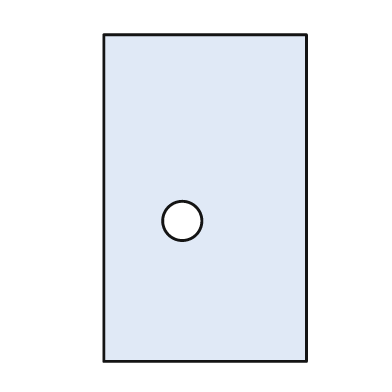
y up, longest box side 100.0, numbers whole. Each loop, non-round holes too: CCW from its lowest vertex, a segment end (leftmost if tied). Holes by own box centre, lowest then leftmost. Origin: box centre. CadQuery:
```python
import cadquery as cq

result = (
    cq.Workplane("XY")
    .moveTo(-31.0, -50.0)
    .lineTo(31.0, -50.0)
    .lineTo(31.0, 50.0)
    .lineTo(-31.0, 50.0)
    .close()
    .moveTo(-7.0, -7.0)
    .circle(6.0)
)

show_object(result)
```